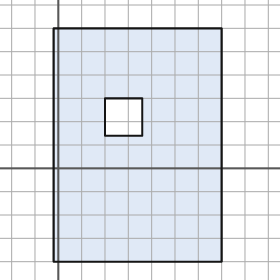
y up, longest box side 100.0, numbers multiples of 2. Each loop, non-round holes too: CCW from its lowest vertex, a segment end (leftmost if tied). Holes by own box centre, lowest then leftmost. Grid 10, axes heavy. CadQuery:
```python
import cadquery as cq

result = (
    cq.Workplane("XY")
    .moveTo(-2.0, -40.0)
    .lineTo(70.0, -40.0)
    .lineTo(70.0, 60.0)
    .lineTo(-2.0, 60.0)
    .close()
    .moveTo(20.0, 14.0)
    .lineTo(36.0, 14.0)
    .lineTo(36.0, 30.0)
    .lineTo(20.0, 30.0)
    .close()
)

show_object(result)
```